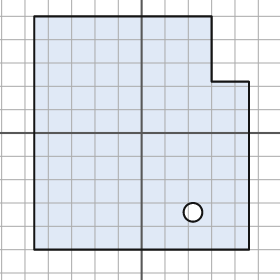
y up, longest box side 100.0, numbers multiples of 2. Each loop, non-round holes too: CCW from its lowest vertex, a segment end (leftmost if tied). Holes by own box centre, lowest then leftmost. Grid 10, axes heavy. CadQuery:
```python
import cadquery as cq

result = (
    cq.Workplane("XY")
    .moveTo(-46.0, -50.0)
    .lineTo(46.0, -50.0)
    .lineTo(46.0, 22.0)
    .lineTo(30.0, 22.0)
    .lineTo(30.0, 50.0)
    .lineTo(-46.0, 50.0)
    .close()
    .moveTo(22.0, -34.0)
    .circle(4.0)
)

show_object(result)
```